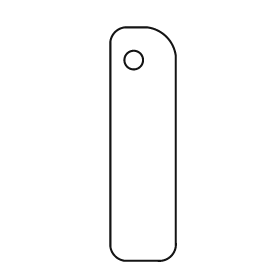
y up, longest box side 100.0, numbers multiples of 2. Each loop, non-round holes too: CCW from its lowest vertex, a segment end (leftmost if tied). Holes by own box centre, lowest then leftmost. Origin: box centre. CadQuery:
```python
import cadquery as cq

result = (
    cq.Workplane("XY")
    .moveTo(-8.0, -50.0)
    .lineTo(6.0, -50.0)
    .threePointArc((12.0, -48.0), (14.0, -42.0))
    .lineTo(14.0, 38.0)
    .threePointArc((10.0, 46.0), (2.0, 50.0))
    .lineTo(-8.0, 50.0)
    .threePointArc((-12.0, 48.0), (-14.0, 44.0))
    .lineTo(-14.0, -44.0)
    .threePointArc((-12.0, -48.0), (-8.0, -50.0))
    .close()
    .moveTo(-4.0, 36.0)
    .circle(4.0)
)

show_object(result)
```